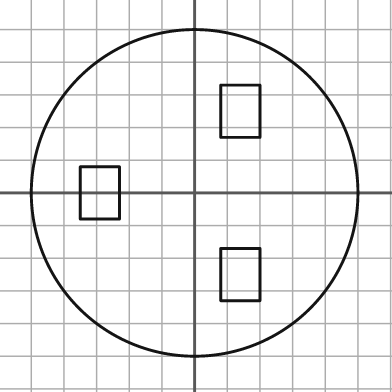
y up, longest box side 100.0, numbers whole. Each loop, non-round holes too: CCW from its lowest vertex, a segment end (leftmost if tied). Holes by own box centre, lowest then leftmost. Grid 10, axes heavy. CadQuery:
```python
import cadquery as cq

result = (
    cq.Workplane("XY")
    .moveTo(0.0, 0.0)
    .circle(50.0)
    .moveTo(8.0, -33.0)
    .lineTo(20.0, -33.0)
    .lineTo(20.0, -17.0)
    .lineTo(8.0, -17.0)
    .close()
    .moveTo(-35.0, -8.0)
    .lineTo(-23.0, -8.0)
    .lineTo(-23.0, 8.0)
    .lineTo(-35.0, 8.0)
    .close()
    .moveTo(8.0, 17.0)
    .lineTo(20.0, 17.0)
    .lineTo(20.0, 33.0)
    .lineTo(8.0, 33.0)
    .close()
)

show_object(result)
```